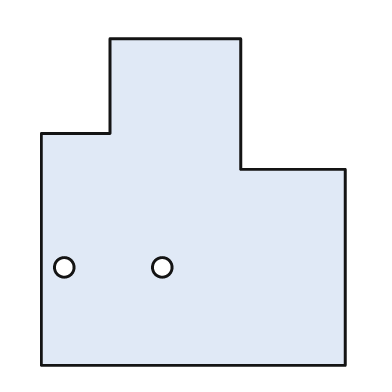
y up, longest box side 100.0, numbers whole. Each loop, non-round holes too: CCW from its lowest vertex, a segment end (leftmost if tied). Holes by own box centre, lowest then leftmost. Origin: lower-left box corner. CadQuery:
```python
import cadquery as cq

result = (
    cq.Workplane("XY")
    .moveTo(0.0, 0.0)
    .lineTo(93.0, 0.0)
    .lineTo(93.0, 60.0)
    .lineTo(61.0, 60.0)
    .lineTo(61.0, 100.0)
    .lineTo(21.0, 100.0)
    .lineTo(21.0, 71.0)
    .lineTo(0.0, 71.0)
    .close()
    .moveTo(7.0, 30.0)
    .circle(3.0)
    .moveTo(37.0, 30.0)
    .circle(3.0)
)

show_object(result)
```